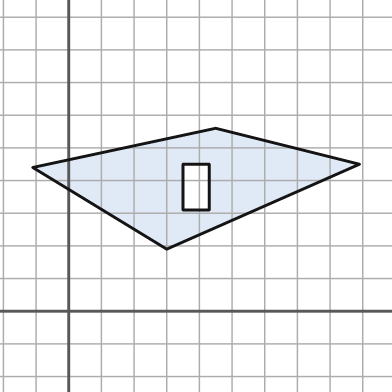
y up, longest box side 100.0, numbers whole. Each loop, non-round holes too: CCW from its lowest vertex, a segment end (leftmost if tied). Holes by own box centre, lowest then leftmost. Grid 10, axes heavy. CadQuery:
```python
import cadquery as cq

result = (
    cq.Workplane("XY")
    .moveTo(30.0, 19.0)
    .lineTo(89.0, 45.0)
    .lineTo(45.0, 56.0)
    .lineTo(-11.0, 44.0)
    .close()
    .moveTo(35.0, 31.0)
    .lineTo(43.0, 31.0)
    .lineTo(43.0, 45.0)
    .lineTo(35.0, 45.0)
    .close()
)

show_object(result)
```